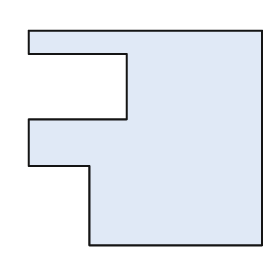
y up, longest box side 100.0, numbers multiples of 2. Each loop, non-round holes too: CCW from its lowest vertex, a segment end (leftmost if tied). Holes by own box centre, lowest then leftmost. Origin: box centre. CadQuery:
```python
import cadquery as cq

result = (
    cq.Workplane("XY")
    .moveTo(-24.0, -46.0)
    .lineTo(50.0, -46.0)
    .lineTo(50.0, 46.0)
    .lineTo(-50.0, 46.0)
    .lineTo(-50.0, 36.0)
    .lineTo(-8.0, 36.0)
    .lineTo(-8.0, 8.0)
    .lineTo(-50.0, 8.0)
    .lineTo(-50.0, -12.0)
    .lineTo(-24.0, -12.0)
    .close()
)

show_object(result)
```